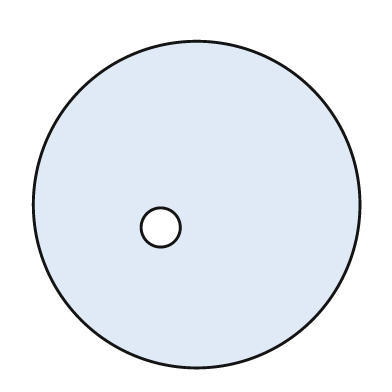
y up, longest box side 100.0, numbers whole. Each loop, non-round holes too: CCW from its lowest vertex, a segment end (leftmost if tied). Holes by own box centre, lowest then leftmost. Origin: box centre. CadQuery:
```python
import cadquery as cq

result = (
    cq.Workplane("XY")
    .moveTo(0.0, 0.0)
    .circle(50.0)
    .moveTo(-11.0, -7.0)
    .circle(6.0)
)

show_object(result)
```